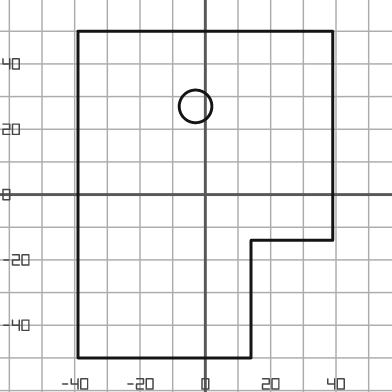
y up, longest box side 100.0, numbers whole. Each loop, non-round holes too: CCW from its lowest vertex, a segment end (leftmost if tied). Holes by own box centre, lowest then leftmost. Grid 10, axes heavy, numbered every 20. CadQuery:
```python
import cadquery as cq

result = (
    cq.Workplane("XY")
    .moveTo(-39.0, -50.0)
    .lineTo(14.0, -50.0)
    .lineTo(14.0, -14.0)
    .lineTo(39.0, -14.0)
    .lineTo(39.0, 50.0)
    .lineTo(-39.0, 50.0)
    .close()
    .moveTo(-3.0, 27.0)
    .circle(5.0)
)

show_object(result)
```